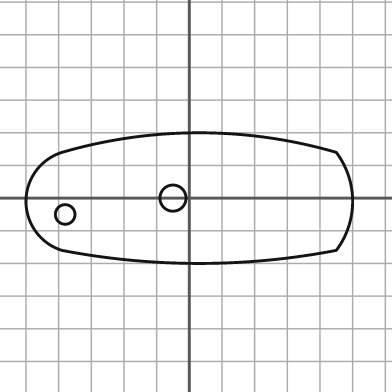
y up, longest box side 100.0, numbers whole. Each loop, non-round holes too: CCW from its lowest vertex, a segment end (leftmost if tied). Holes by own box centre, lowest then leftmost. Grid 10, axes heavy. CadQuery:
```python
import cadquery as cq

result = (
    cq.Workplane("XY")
    .moveTo(-39.0, -16.0)
    .threePointArc((3.0, -20.0), (45.0, -16.0))
    .threePointArc((50.0, -1.0), (45.0, 14.0))
    .threePointArc((3.0, 20.0), (-39.0, 14.0))
    .threePointArc((-50.0, -1.0), (-39.0, -16.0))
    .close()
    .moveTo(-38.0, -5.0)
    .circle(3.0)
    .moveTo(-5.0, 0.0)
    .circle(4.0)
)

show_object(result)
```